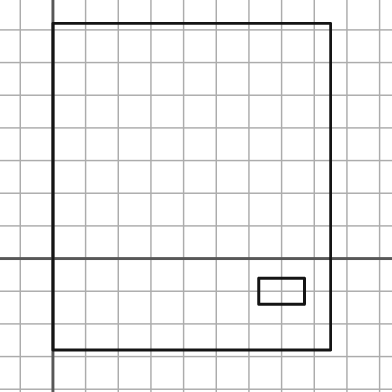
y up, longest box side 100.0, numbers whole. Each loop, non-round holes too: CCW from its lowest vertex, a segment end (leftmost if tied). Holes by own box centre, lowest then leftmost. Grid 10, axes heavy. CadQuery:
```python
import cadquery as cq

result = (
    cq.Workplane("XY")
    .moveTo(0.0, -28.0)
    .lineTo(85.0, -28.0)
    .lineTo(85.0, 72.0)
    .lineTo(0.0, 72.0)
    .close()
    .moveTo(63.0, -14.0)
    .lineTo(77.0, -14.0)
    .lineTo(77.0, -6.0)
    .lineTo(63.0, -6.0)
    .close()
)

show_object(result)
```